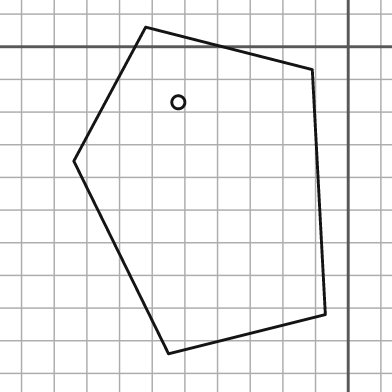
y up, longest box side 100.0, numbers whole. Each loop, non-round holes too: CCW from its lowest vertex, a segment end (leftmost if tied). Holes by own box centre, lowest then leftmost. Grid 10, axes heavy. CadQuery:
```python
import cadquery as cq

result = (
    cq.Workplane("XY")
    .moveTo(-55.0, -94.0)
    .lineTo(-7.0, -82.0)
    .lineTo(-11.0, -7.0)
    .lineTo(-62.0, 6.0)
    .lineTo(-84.0, -35.0)
    .close()
    .moveTo(-52.0, -17.0)
    .circle(2.0)
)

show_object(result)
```